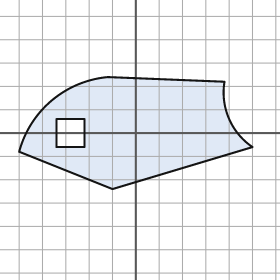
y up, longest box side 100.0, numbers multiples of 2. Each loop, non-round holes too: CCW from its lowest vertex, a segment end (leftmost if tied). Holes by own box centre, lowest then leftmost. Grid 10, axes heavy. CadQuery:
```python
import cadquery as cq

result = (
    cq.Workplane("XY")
    .moveTo(-10.0, -24.0)
    .lineTo(50.0, -6.0)
    .threePointArc((40.0, 6.0), (38.0, 22.0))
    .lineTo(-12.0, 24.0)
    .threePointArc((-36.0, 14.0), (-50.0, -8.0))
    .close()
    .moveTo(-34.0, -6.0)
    .lineTo(-22.0, -6.0)
    .lineTo(-22.0, 6.0)
    .lineTo(-34.0, 6.0)
    .close()
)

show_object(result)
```